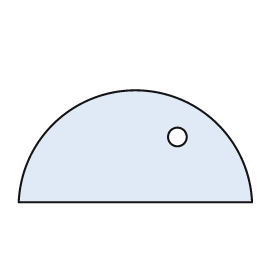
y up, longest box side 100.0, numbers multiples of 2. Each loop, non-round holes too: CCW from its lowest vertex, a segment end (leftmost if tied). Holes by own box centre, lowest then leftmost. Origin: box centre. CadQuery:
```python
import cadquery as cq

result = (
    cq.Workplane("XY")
    .moveTo(-50.0, -24.0)
    .lineTo(50.0, -24.0)
    .threePointArc((0.0, 24.0), (-50.0, -24.0))
    .close()
    .moveTo(18.0, 4.0)
    .circle(4.0)
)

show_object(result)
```